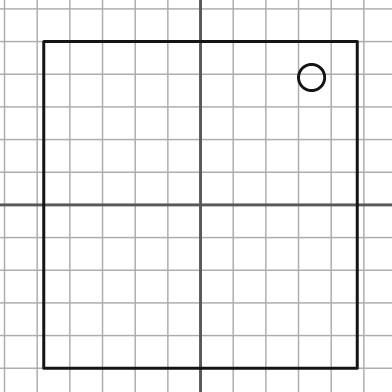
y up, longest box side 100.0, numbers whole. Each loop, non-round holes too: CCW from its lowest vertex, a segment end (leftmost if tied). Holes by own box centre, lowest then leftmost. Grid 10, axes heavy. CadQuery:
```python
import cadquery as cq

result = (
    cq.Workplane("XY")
    .moveTo(-48.0, -50.0)
    .lineTo(48.0, -50.0)
    .lineTo(48.0, 50.0)
    .lineTo(-48.0, 50.0)
    .close()
    .moveTo(34.0, 39.0)
    .circle(4.0)
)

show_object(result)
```